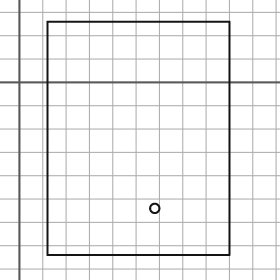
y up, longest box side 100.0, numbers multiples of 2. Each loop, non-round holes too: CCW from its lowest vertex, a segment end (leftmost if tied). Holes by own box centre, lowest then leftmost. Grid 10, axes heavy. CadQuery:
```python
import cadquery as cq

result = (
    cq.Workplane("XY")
    .moveTo(12.0, -74.0)
    .lineTo(90.0, -74.0)
    .lineTo(90.0, 26.0)
    .lineTo(12.0, 26.0)
    .close()
    .moveTo(58.0, -54.0)
    .circle(2.0)
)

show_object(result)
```